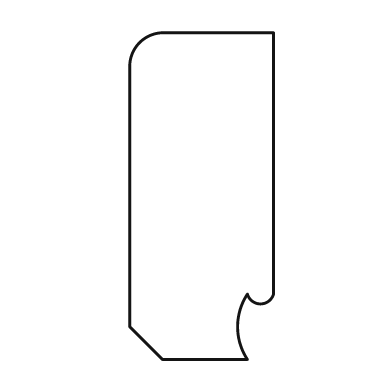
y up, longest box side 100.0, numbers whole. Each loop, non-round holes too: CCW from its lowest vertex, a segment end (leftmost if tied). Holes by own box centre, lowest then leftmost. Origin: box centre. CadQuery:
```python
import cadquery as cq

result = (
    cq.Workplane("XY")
    .moveTo(-12.0, -50.0)
    .lineTo(14.0, -50.0)
    .threePointArc((11.0, -40.0), (14.0, -30.0))
    .threePointArc((18.0, -33.0), (22.0, -30.0))
    .lineTo(22.0, 50.0)
    .lineTo(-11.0, 50.0)
    .threePointArc((-19.0, 47.0), (-22.0, 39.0))
    .lineTo(-22.0, -40.0)
    .close()
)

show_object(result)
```